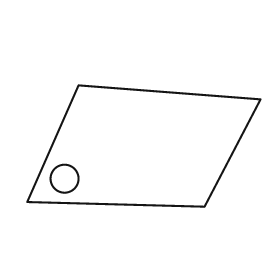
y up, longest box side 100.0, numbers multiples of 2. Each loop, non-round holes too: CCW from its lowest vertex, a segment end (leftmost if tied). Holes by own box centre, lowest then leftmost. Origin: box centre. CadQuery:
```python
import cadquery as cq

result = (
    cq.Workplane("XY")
    .moveTo(26.0, -26.0)
    .lineTo(50.0, 20.0)
    .lineTo(-28.0, 26.0)
    .lineTo(-50.0, -24.0)
    .close()
    .moveTo(-34.0, -14.0)
    .circle(6.0)
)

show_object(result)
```